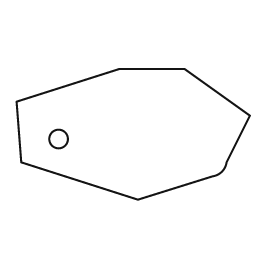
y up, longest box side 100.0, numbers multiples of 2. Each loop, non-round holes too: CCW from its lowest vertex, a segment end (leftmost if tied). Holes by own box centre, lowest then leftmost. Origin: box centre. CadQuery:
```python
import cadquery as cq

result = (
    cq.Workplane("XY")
    .moveTo(2.0, -28.0)
    .lineTo(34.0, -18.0)
    .threePointArc((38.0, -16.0), (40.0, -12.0))
    .lineTo(50.0, 8.0)
    .lineTo(22.0, 28.0)
    .lineTo(-6.0, 28.0)
    .lineTo(-50.0, 14.0)
    .lineTo(-48.0, -12.0)
    .close()
    .moveTo(-32.0, -2.0)
    .circle(4.0)
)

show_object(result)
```